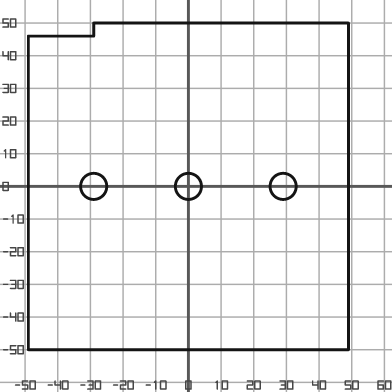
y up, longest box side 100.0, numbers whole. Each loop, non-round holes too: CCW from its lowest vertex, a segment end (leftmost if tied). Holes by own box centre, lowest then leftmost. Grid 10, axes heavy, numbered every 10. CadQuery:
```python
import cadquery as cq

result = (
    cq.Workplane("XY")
    .moveTo(-49.0, -50.0)
    .lineTo(49.0, -50.0)
    .lineTo(49.0, 50.0)
    .lineTo(-29.0, 50.0)
    .lineTo(-29.0, 46.0)
    .lineTo(-49.0, 46.0)
    .close()
    .moveTo(-29.0, 0.0)
    .circle(4.0)
    .moveTo(0.0, 0.0)
    .circle(4.0)
    .moveTo(29.0, 0.0)
    .circle(4.0)
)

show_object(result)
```